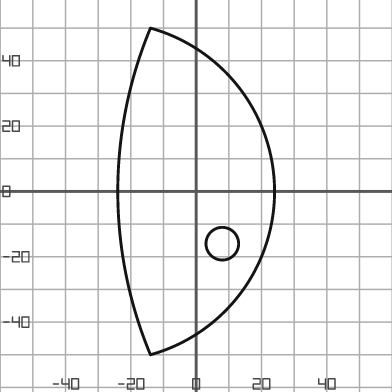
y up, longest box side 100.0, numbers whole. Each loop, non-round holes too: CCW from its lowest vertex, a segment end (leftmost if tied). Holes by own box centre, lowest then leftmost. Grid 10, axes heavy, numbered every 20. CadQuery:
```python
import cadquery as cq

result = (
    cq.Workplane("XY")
    .moveTo(-14.0, -50.0)
    .threePointArc((24.0, 0.0), (-14.0, 50.0))
    .threePointArc((-24.0, 0.0), (-14.0, -50.0))
    .close()
    .moveTo(8.0, -16.0)
    .circle(5.0)
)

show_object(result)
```